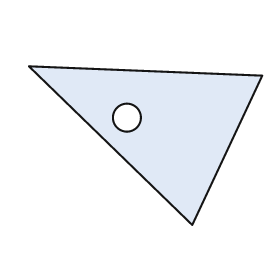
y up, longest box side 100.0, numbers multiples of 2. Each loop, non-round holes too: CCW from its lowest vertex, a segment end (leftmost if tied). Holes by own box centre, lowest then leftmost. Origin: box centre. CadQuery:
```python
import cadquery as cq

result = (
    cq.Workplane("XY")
    .moveTo(20.0, -34.0)
    .lineTo(50.0, 30.0)
    .lineTo(-50.0, 34.0)
    .close()
    .moveTo(-8.0, 12.0)
    .circle(6.0)
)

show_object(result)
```